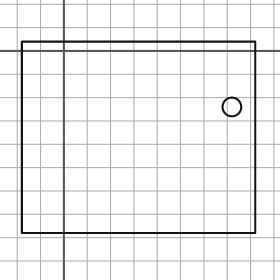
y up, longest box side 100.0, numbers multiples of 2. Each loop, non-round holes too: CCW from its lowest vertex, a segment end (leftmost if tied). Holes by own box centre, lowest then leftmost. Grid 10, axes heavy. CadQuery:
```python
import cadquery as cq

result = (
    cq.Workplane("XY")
    .moveTo(-18.0, -78.0)
    .lineTo(82.0, -78.0)
    .lineTo(82.0, 4.0)
    .lineTo(-18.0, 4.0)
    .close()
    .moveTo(72.0, -24.0)
    .circle(4.0)
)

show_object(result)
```